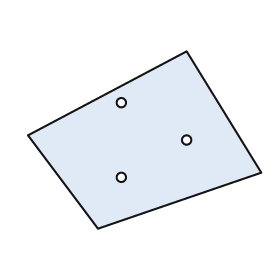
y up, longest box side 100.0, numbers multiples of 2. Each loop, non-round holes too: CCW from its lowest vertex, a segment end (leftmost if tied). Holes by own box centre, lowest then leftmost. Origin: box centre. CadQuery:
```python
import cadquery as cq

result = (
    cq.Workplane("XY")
    .moveTo(-20.0, -38.0)
    .lineTo(50.0, -14.0)
    .lineTo(18.0, 38.0)
    .lineTo(-50.0, 2.0)
    .close()
    .moveTo(-10.0, -16.0)
    .circle(2.0)
    .moveTo(18.0, 0.0)
    .circle(2.0)
    .moveTo(-10.0, 16.0)
    .circle(2.0)
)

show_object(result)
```